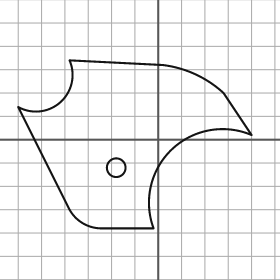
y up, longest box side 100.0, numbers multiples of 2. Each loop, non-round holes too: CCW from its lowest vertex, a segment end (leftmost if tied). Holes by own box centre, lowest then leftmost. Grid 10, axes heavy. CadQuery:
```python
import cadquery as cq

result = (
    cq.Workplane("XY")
    .moveTo(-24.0, -38.0)
    .lineTo(-2.0, -38.0)
    .threePointArc((6.0, -4.0), (40.0, 2.0))
    .lineTo(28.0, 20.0)
    .threePointArc((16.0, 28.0), (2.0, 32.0))
    .lineTo(-38.0, 34.0)
    .threePointArc((-42.0, 16.0), (-60.0, 14.0))
    .lineTo(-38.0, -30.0)
    .threePointArc((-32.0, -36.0), (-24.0, -38.0))
    .close()
    .moveTo(-18.0, -12.0)
    .circle(4.0)
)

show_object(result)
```